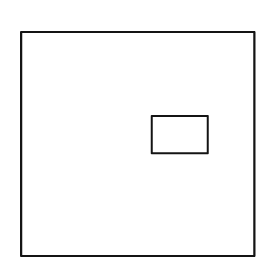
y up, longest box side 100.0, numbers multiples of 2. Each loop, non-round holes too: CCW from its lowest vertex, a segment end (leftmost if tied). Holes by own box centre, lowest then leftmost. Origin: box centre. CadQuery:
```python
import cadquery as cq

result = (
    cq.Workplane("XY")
    .moveTo(-50.0, -48.0)
    .lineTo(50.0, -48.0)
    .lineTo(50.0, 48.0)
    .lineTo(-50.0, 48.0)
    .close()
    .moveTo(6.0, -4.0)
    .lineTo(30.0, -4.0)
    .lineTo(30.0, 12.0)
    .lineTo(6.0, 12.0)
    .close()
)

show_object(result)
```